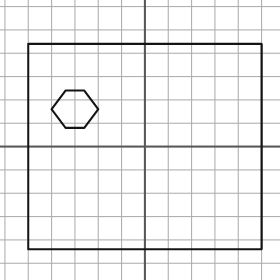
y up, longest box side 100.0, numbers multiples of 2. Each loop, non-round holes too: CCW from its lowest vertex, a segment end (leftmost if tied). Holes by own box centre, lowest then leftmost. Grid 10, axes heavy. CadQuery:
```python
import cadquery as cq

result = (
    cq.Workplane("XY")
    .moveTo(-50.0, -44.0)
    .lineTo(50.0, -44.0)
    .lineTo(50.0, 44.0)
    .lineTo(-50.0, 44.0)
    .close()
    .moveTo(-34.0, 8.0)
    .lineTo(-26.0, 8.0)
    .lineTo(-20.0, 16.0)
    .lineTo(-26.0, 24.0)
    .lineTo(-34.0, 24.0)
    .lineTo(-40.0, 16.0)
    .close()
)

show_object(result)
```